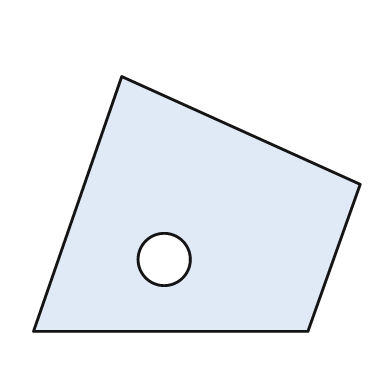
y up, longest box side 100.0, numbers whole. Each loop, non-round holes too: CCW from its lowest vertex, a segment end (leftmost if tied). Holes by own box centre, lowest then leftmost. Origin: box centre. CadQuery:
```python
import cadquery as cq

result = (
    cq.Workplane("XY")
    .moveTo(-50.0, -39.0)
    .lineTo(34.0, -39.0)
    .lineTo(50.0, 6.0)
    .lineTo(-23.0, 39.0)
    .close()
    .moveTo(-10.0, -17.0)
    .circle(8.0)
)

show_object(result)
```